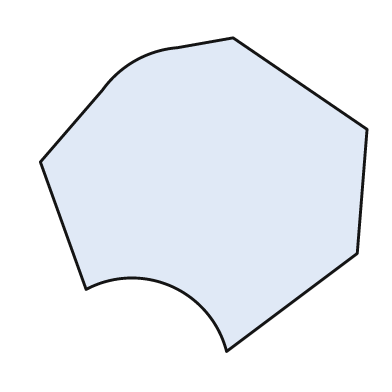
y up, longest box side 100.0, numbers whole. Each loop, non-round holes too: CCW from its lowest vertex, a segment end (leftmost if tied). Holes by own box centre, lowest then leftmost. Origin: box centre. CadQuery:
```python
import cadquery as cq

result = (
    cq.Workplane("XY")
    .moveTo(7.0, -48.0)
    .lineTo(47.0, -18.0)
    .lineTo(50.0, 20.0)
    .lineTo(9.0, 48.0)
    .lineTo(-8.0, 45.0)
    .threePointArc((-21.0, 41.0), (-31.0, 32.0))
    .lineTo(-50.0, 10.0)
    .lineTo(-36.0, -29.0)
    .threePointArc((-10.0, -28.0), (7.0, -48.0))
    .close()
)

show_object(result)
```